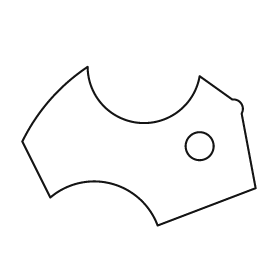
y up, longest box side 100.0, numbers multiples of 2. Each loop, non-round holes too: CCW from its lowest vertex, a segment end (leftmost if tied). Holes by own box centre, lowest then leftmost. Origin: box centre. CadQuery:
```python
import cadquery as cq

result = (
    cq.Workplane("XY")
    .moveTo(8.0, -34.0)
    .lineTo(50.0, -18.0)
    .lineTo(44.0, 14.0)
    .threePointArc((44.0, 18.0), (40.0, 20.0))
    .lineTo(26.0, 30.0)
    .threePointArc((0.0, 10.0), (-22.0, 34.0))
    .threePointArc((-38.0, 20.0), (-50.0, 2.0))
    .lineTo(-38.0, -22.0)
    .threePointArc((-12.0, -16.0), (8.0, -34.0))
    .close()
    .moveTo(26.0, 0.0)
    .circle(6.0)
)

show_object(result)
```